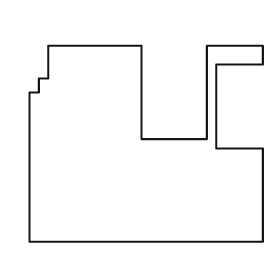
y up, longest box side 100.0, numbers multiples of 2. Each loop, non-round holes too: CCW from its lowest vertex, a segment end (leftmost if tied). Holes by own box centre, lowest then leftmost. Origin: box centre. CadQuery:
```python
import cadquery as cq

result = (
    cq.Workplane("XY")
    .moveTo(-50.0, -42.0)
    .lineTo(50.0, -42.0)
    .lineTo(50.0, -2.0)
    .lineTo(30.0, -2.0)
    .lineTo(30.0, 34.0)
    .lineTo(50.0, 34.0)
    .lineTo(50.0, 42.0)
    .lineTo(26.0, 42.0)
    .lineTo(26.0, 2.0)
    .lineTo(-2.0, 2.0)
    .lineTo(-2.0, 42.0)
    .lineTo(-42.0, 42.0)
    .lineTo(-42.0, 28.0)
    .lineTo(-46.0, 28.0)
    .lineTo(-46.0, 22.0)
    .lineTo(-50.0, 22.0)
    .close()
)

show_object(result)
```